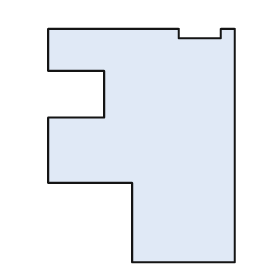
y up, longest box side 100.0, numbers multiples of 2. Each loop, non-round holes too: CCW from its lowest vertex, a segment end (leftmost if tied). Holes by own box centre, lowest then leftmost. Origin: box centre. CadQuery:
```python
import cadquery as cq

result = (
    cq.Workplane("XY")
    .moveTo(-4.0, -50.0)
    .lineTo(40.0, -50.0)
    .lineTo(40.0, 50.0)
    .lineTo(34.0, 50.0)
    .lineTo(34.0, 46.0)
    .lineTo(16.0, 46.0)
    .lineTo(16.0, 50.0)
    .lineTo(-40.0, 50.0)
    .lineTo(-40.0, 32.0)
    .lineTo(-16.0, 32.0)
    .lineTo(-16.0, 12.0)
    .lineTo(-40.0, 12.0)
    .lineTo(-40.0, -16.0)
    .lineTo(-4.0, -16.0)
    .close()
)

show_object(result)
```